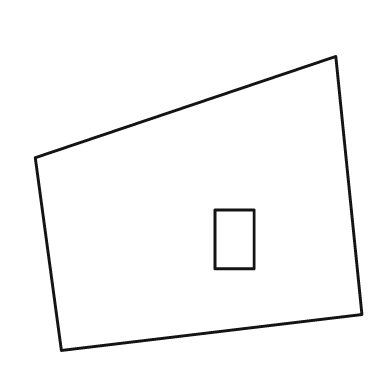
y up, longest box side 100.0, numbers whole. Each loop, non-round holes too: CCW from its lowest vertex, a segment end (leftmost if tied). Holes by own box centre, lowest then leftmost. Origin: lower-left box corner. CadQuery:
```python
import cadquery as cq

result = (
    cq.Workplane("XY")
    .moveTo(8.0, 0.0)
    .lineTo(100.0, 11.0)
    .lineTo(92.0, 90.0)
    .lineTo(0.0, 59.0)
    .close()
    .moveTo(55.0, 25.0)
    .lineTo(67.0, 25.0)
    .lineTo(67.0, 43.0)
    .lineTo(55.0, 43.0)
    .close()
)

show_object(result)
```